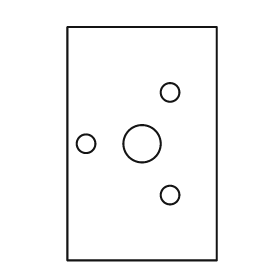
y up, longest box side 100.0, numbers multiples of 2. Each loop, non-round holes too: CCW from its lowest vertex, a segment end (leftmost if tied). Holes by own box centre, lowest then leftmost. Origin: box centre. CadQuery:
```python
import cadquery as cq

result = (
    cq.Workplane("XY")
    .moveTo(-32.0, -50.0)
    .lineTo(32.0, -50.0)
    .lineTo(32.0, 50.0)
    .lineTo(-32.0, 50.0)
    .close()
    .moveTo(12.0, -22.0)
    .circle(4.0)
    .moveTo(-24.0, 0.0)
    .circle(4.0)
    .moveTo(0.0, 0.0)
    .circle(8.0)
    .moveTo(12.0, 22.0)
    .circle(4.0)
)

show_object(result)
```